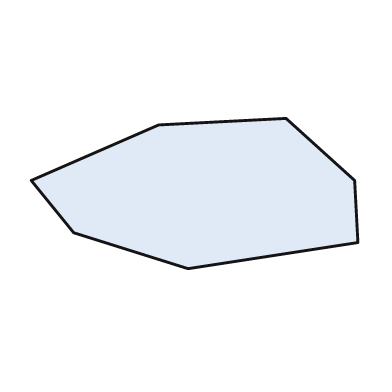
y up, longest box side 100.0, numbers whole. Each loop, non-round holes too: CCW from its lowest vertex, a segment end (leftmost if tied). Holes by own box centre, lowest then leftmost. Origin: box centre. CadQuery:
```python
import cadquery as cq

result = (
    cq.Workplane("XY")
    .moveTo(-2.0, -23.0)
    .lineTo(50.0, -15.0)
    .lineTo(49.0, 4.0)
    .lineTo(28.0, 23.0)
    .lineTo(-11.0, 21.0)
    .lineTo(-50.0, 4.0)
    .lineTo(-37.0, -12.0)
    .close()
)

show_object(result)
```